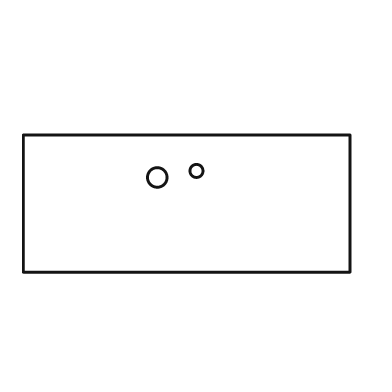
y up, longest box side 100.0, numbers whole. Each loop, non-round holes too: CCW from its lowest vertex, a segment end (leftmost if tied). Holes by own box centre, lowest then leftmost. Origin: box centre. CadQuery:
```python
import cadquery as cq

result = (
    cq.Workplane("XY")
    .moveTo(-50.0, -21.0)
    .lineTo(50.0, -21.0)
    .lineTo(50.0, 21.0)
    .lineTo(-50.0, 21.0)
    .close()
    .moveTo(-9.0, 8.0)
    .circle(3.0)
    .moveTo(3.0, 10.0)
    .circle(2.0)
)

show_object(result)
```